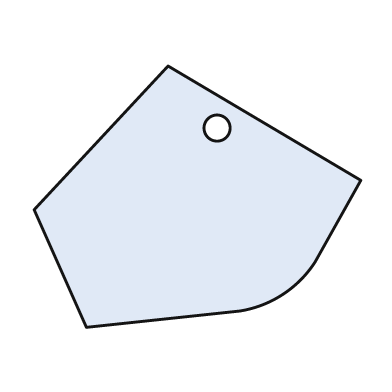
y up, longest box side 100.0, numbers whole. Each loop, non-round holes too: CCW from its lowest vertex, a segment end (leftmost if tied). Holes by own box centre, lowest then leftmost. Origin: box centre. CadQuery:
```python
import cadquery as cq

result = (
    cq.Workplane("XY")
    .moveTo(-34.0, -40.0)
    .lineTo(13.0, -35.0)
    .threePointArc((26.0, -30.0), (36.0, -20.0))
    .lineTo(50.0, 5.0)
    .lineTo(-9.0, 40.0)
    .lineTo(-50.0, -4.0)
    .close()
    .moveTo(6.0, 21.0)
    .circle(4.0)
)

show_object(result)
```